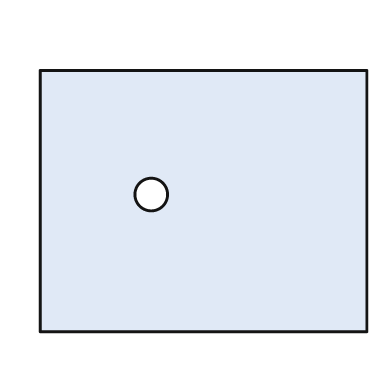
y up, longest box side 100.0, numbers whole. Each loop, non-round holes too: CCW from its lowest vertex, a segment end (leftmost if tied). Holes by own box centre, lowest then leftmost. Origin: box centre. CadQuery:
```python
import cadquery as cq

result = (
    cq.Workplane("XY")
    .moveTo(-50.0, -40.0)
    .lineTo(50.0, -40.0)
    .lineTo(50.0, 40.0)
    .lineTo(-50.0, 40.0)
    .close()
    .moveTo(-16.0, 2.0)
    .circle(5.0)
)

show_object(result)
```